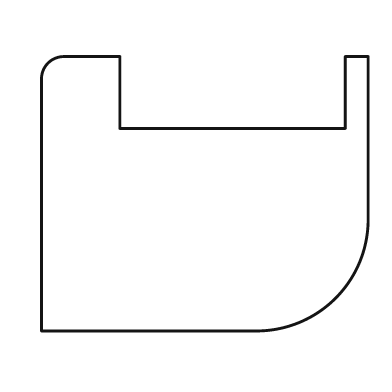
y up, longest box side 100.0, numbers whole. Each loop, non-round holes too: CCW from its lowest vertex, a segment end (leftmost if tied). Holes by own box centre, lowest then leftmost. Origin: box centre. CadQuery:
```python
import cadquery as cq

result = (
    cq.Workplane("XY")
    .moveTo(-50.0, -42.0)
    .lineTo(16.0, -42.0)
    .threePointArc((40.0, -32.0), (50.0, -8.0))
    .lineTo(50.0, 42.0)
    .lineTo(43.0, 42.0)
    .lineTo(43.0, 20.0)
    .lineTo(-26.0, 20.0)
    .lineTo(-26.0, 42.0)
    .lineTo(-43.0, 42.0)
    .threePointArc((-48.0, 40.0), (-50.0, 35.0))
    .close()
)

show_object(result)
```